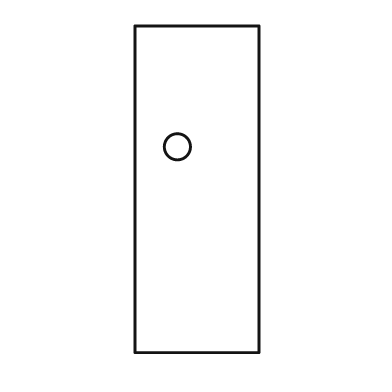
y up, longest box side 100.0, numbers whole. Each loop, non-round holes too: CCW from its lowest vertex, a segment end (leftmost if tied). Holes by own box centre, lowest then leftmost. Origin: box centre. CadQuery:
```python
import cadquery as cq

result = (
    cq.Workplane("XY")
    .moveTo(-19.0, -50.0)
    .lineTo(19.0, -50.0)
    .lineTo(19.0, 50.0)
    .lineTo(-19.0, 50.0)
    .close()
    .moveTo(-6.0, 13.0)
    .circle(4.0)
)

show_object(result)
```